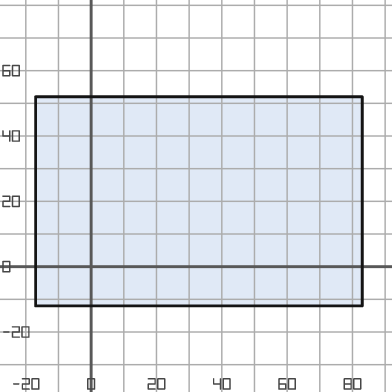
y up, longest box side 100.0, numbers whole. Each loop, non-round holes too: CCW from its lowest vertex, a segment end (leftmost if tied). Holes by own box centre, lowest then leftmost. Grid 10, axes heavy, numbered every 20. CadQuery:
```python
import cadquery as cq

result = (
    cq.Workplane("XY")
    .moveTo(-17.0, -12.0)
    .lineTo(83.0, -12.0)
    .lineTo(83.0, 52.0)
    .lineTo(-17.0, 52.0)
    .close()
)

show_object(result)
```